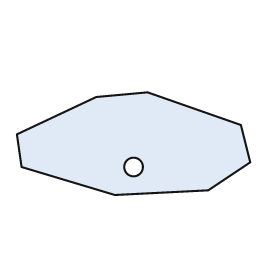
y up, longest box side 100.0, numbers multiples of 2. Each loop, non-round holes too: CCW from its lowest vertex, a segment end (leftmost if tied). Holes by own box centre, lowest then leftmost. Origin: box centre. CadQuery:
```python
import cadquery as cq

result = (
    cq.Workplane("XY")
    .moveTo(-8.0, -22.0)
    .lineTo(32.0, -20.0)
    .lineTo(50.0, -8.0)
    .lineTo(46.0, 8.0)
    .lineTo(6.0, 22.0)
    .lineTo(-16.0, 20.0)
    .lineTo(-50.0, 4.0)
    .lineTo(-48.0, -10.0)
    .close()
    .moveTo(0.0, -10.0)
    .circle(4.0)
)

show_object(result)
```